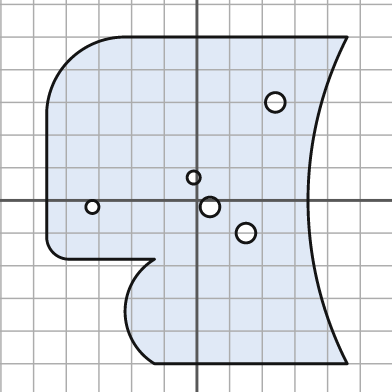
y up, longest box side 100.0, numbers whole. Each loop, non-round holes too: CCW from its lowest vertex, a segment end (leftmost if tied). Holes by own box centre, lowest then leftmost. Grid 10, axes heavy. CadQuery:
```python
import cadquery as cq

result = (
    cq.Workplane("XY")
    .moveTo(-13.0, -50.0)
    .lineTo(46.0, -50.0)
    .threePointArc((34.0, 0.0), (46.0, 50.0))
    .lineTo(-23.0, 50.0)
    .threePointArc((-39.0, 43.0), (-46.0, 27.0))
    .lineTo(-46.0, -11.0)
    .threePointArc((-44.0, -16.0), (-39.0, -18.0))
    .lineTo(-13.0, -18.0)
    .threePointArc((-22.0, -34.0), (-13.0, -50.0))
    .close()
    .moveTo(15.0, -10.0)
    .circle(3.0)
    .moveTo(-32.0, -2.0)
    .circle(2.0)
    .moveTo(4.0, -2.0)
    .circle(3.0)
    .moveTo(-1.0, 7.0)
    .circle(2.0)
    .moveTo(24.0, 30.0)
    .circle(3.0)
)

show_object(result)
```